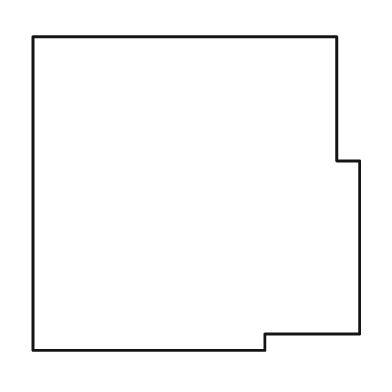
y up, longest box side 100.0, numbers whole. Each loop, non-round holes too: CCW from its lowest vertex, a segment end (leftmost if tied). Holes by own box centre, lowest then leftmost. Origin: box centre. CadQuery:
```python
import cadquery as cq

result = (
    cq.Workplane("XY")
    .moveTo(-50.0, -48.0)
    .lineTo(21.0, -48.0)
    .lineTo(21.0, -43.0)
    .lineTo(50.0, -43.0)
    .lineTo(50.0, 10.0)
    .lineTo(43.0, 10.0)
    .lineTo(43.0, 48.0)
    .lineTo(-50.0, 48.0)
    .close()
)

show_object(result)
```